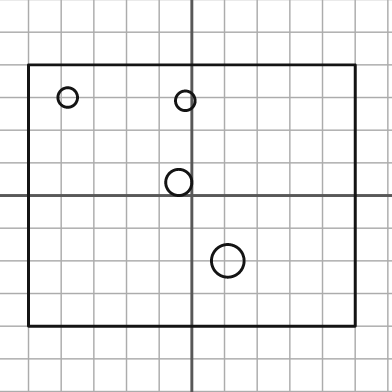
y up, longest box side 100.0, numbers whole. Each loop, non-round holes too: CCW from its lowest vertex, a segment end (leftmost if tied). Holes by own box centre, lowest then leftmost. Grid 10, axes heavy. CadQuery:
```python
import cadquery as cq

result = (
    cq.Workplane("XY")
    .moveTo(-50.0, -40.0)
    .lineTo(50.0, -40.0)
    .lineTo(50.0, 40.0)
    .lineTo(-50.0, 40.0)
    .close()
    .moveTo(11.0, -20.0)
    .circle(5.0)
    .moveTo(-4.0, 4.0)
    .circle(4.0)
    .moveTo(-2.0, 29.0)
    .circle(3.0)
    .moveTo(-38.0, 30.0)
    .circle(3.0)
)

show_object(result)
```